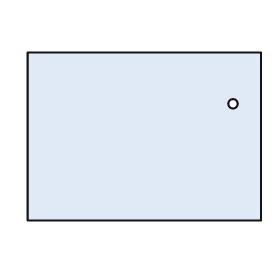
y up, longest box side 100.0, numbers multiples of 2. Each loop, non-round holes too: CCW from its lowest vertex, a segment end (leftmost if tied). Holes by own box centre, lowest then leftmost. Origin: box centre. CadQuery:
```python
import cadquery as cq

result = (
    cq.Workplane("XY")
    .moveTo(-50.0, -36.0)
    .lineTo(50.0, -36.0)
    .lineTo(50.0, 36.0)
    .lineTo(-50.0, 36.0)
    .close()
    .moveTo(38.0, 14.0)
    .circle(2.0)
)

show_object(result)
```